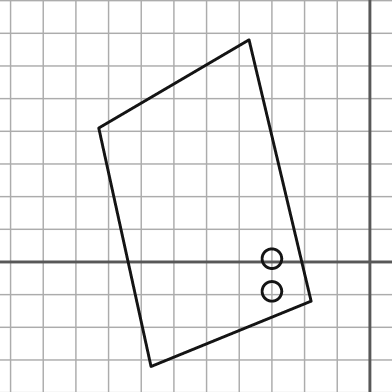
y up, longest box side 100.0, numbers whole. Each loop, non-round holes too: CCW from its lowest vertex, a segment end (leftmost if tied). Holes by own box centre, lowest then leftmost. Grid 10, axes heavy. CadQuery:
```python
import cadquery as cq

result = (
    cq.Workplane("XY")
    .moveTo(-67.0, -32.0)
    .lineTo(-18.0, -12.0)
    .lineTo(-37.0, 68.0)
    .lineTo(-83.0, 41.0)
    .close()
    .moveTo(-30.0, -9.0)
    .circle(3.0)
    .moveTo(-30.0, 1.0)
    .circle(3.0)
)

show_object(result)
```